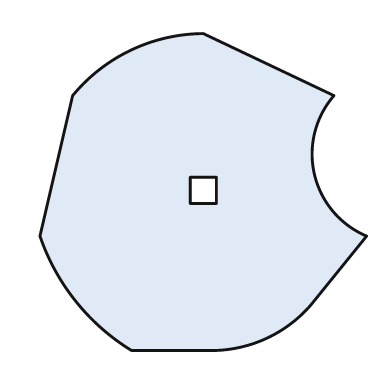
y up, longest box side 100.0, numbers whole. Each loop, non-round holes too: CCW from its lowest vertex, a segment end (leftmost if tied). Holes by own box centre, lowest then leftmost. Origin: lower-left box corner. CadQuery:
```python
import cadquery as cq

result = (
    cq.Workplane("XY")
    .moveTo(28.0, 0.0)
    .lineTo(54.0, 0.0)
    .threePointArc((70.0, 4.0), (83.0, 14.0))
    .lineTo(100.0, 35.0)
    .threePointArc((84.0, 54.0), (90.0, 78.0))
    .lineTo(50.0, 97.0)
    .threePointArc((28.0, 92.0), (10.0, 78.0))
    .lineTo(0.0, 35.0)
    .threePointArc((11.0, 15.0), (28.0, 0.0))
    .close()
    .moveTo(46.0, 45.0)
    .lineTo(54.0, 45.0)
    .lineTo(54.0, 53.0)
    .lineTo(46.0, 53.0)
    .close()
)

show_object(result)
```